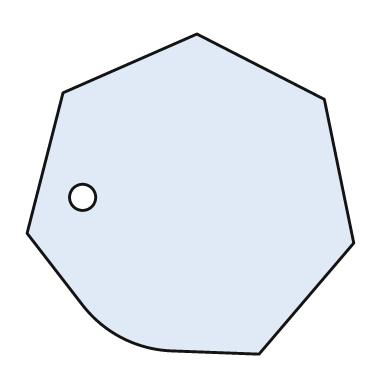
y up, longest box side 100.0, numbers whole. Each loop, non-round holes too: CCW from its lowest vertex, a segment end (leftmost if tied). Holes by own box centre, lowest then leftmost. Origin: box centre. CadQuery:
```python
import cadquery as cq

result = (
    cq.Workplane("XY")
    .moveTo(21.0, -49.0)
    .lineTo(50.0, -15.0)
    .lineTo(41.0, 29.0)
    .lineTo(2.0, 49.0)
    .lineTo(-39.0, 31.0)
    .lineTo(-50.0, -12.0)
    .lineTo(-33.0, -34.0)
    .threePointArc((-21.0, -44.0), (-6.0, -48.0))
    .close()
    .moveTo(-33.0, -1.0)
    .circle(4.0)
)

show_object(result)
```